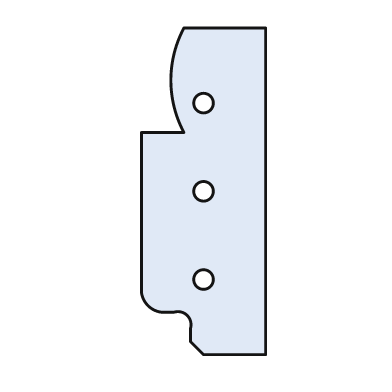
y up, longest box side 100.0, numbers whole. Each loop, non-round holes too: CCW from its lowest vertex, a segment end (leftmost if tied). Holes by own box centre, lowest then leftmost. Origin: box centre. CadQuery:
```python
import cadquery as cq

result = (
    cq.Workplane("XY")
    .moveTo(0.0, -50.0)
    .lineTo(19.0, -50.0)
    .lineTo(19.0, 50.0)
    .lineTo(-6.0, 50.0)
    .threePointArc((-10.0, 34.0), (-6.0, 18.0))
    .lineTo(-19.0, 18.0)
    .lineTo(-19.0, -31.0)
    .threePointArc((-17.0, -35.0), (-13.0, -37.0))
    .lineTo(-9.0, -37.0)
    .threePointArc((-5.0, -38.0), (-4.0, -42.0))
    .lineTo(-4.0, -46.0)
    .close()
    .moveTo(0.0, -27.0)
    .circle(3.0)
    .moveTo(0.0, 0.0)
    .circle(3.0)
    .moveTo(0.0, 27.0)
    .circle(3.0)
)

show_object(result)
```